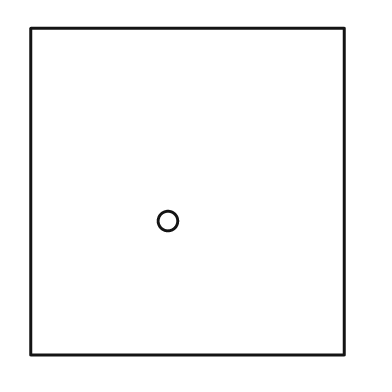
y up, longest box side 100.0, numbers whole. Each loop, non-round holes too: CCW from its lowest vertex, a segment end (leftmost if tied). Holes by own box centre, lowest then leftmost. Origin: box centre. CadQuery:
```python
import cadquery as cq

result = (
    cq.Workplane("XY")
    .moveTo(-48.0, -50.0)
    .lineTo(48.0, -50.0)
    .lineTo(48.0, 50.0)
    .lineTo(-48.0, 50.0)
    .close()
    .moveTo(-6.0, -9.0)
    .circle(3.0)
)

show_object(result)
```